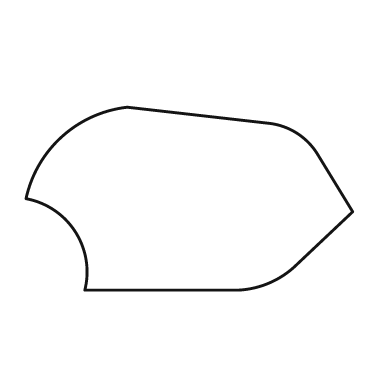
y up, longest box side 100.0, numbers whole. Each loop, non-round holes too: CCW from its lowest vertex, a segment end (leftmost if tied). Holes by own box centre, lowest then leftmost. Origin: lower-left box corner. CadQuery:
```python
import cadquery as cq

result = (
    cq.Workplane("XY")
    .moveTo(18.0, 0.0)
    .lineTo(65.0, 0.0)
    .threePointArc((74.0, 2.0), (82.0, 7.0))
    .lineTo(100.0, 24.0)
    .lineTo(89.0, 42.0)
    .threePointArc((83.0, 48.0), (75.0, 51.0))
    .lineTo(31.0, 56.0)
    .threePointArc((11.0, 47.0), (0.0, 28.0))
    .threePointArc((15.0, 18.0), (18.0, 0.0))
    .close()
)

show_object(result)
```